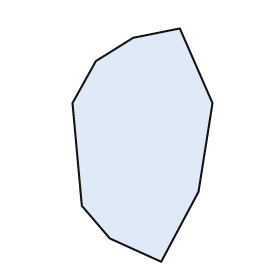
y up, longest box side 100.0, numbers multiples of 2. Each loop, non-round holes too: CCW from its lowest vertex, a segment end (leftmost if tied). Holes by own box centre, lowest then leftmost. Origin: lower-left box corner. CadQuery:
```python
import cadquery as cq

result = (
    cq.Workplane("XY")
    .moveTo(38.0, 0.0)
    .lineTo(54.0, 30.0)
    .lineTo(60.0, 68.0)
    .lineTo(46.0, 100.0)
    .lineTo(26.0, 96.0)
    .lineTo(10.0, 86.0)
    .lineTo(0.0, 68.0)
    .lineTo(4.0, 24.0)
    .lineTo(16.0, 10.0)
    .close()
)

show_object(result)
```